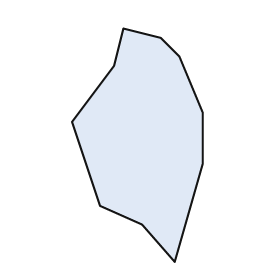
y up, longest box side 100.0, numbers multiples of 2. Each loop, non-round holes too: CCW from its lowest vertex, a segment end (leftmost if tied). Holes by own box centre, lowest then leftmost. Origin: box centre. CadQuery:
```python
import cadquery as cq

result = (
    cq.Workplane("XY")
    .moveTo(16.0, -50.0)
    .lineTo(28.0, -8.0)
    .lineTo(28.0, 14.0)
    .lineTo(18.0, 38.0)
    .lineTo(10.0, 46.0)
    .lineTo(-6.0, 50.0)
    .lineTo(-10.0, 34.0)
    .lineTo(-28.0, 10.0)
    .lineTo(-16.0, -26.0)
    .lineTo(2.0, -34.0)
    .close()
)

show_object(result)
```